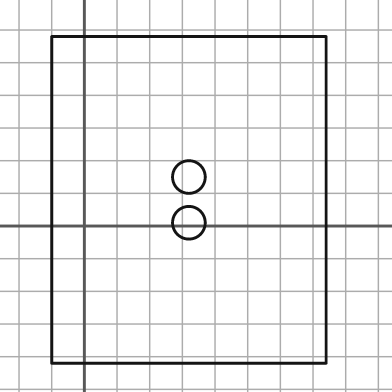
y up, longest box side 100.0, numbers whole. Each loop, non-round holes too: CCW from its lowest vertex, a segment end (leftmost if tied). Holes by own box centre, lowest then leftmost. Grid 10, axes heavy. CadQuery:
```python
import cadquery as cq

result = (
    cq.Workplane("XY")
    .moveTo(-10.0, -42.0)
    .lineTo(74.0, -42.0)
    .lineTo(74.0, 58.0)
    .lineTo(-10.0, 58.0)
    .close()
    .moveTo(32.0, 1.0)
    .circle(5.0)
    .moveTo(32.0, 15.0)
    .circle(5.0)
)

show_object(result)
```